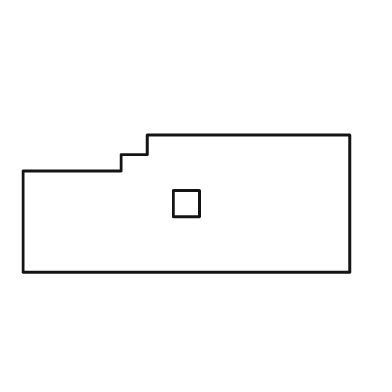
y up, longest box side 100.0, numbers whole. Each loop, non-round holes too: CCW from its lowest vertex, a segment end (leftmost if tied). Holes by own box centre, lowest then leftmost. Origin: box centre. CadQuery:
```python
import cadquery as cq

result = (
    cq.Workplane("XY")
    .moveTo(-50.0, -21.0)
    .lineTo(50.0, -21.0)
    .lineTo(50.0, 21.0)
    .lineTo(-12.0, 21.0)
    .lineTo(-12.0, 15.0)
    .lineTo(-20.0, 15.0)
    .lineTo(-20.0, 10.0)
    .lineTo(-50.0, 10.0)
    .close()
    .moveTo(-4.0, -4.0)
    .lineTo(4.0, -4.0)
    .lineTo(4.0, 4.0)
    .lineTo(-4.0, 4.0)
    .close()
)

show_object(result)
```